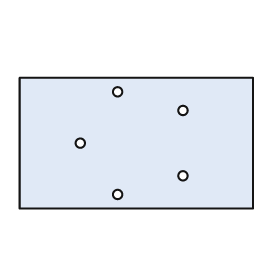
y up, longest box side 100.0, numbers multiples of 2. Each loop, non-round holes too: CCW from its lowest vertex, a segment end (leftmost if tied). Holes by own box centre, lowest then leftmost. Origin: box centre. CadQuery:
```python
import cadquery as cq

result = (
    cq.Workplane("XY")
    .moveTo(-50.0, -28.0)
    .lineTo(50.0, -28.0)
    .lineTo(50.0, 28.0)
    .lineTo(-50.0, 28.0)
    .close()
    .moveTo(-8.0, -22.0)
    .circle(2.0)
    .moveTo(20.0, -14.0)
    .circle(2.0)
    .moveTo(-24.0, 0.0)
    .circle(2.0)
    .moveTo(20.0, 14.0)
    .circle(2.0)
    .moveTo(-8.0, 22.0)
    .circle(2.0)
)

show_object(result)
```